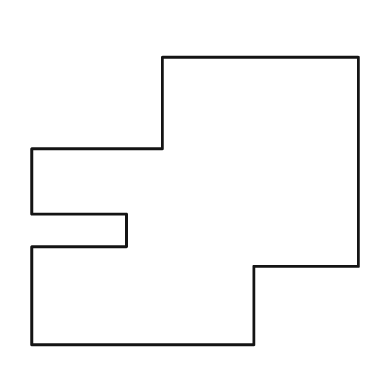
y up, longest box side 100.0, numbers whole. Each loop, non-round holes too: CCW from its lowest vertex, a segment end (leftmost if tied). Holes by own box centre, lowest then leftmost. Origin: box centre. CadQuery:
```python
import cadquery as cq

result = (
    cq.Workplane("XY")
    .moveTo(-50.0, -44.0)
    .lineTo(18.0, -44.0)
    .lineTo(18.0, -20.0)
    .lineTo(50.0, -20.0)
    .lineTo(50.0, 44.0)
    .lineTo(-10.0, 44.0)
    .lineTo(-10.0, 16.0)
    .lineTo(-50.0, 16.0)
    .lineTo(-50.0, -4.0)
    .lineTo(-21.0, -4.0)
    .lineTo(-21.0, -14.0)
    .lineTo(-50.0, -14.0)
    .close()
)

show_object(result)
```